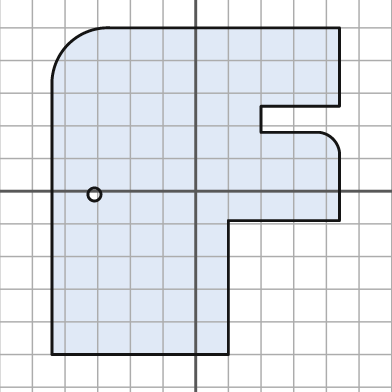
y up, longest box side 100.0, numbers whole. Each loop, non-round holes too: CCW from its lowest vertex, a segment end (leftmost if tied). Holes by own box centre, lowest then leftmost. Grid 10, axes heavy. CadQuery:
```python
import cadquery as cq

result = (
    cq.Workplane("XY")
    .moveTo(-44.0, -50.0)
    .lineTo(10.0, -50.0)
    .lineTo(10.0, -9.0)
    .lineTo(44.0, -9.0)
    .lineTo(44.0, 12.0)
    .threePointArc((42.0, 16.0), (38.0, 18.0))
    .lineTo(20.0, 18.0)
    .lineTo(20.0, 26.0)
    .lineTo(44.0, 26.0)
    .lineTo(44.0, 50.0)
    .lineTo(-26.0, 50.0)
    .threePointArc((-39.0, 45.0), (-44.0, 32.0))
    .close()
    .moveTo(-31.0, -1.0)
    .circle(2.0)
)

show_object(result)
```